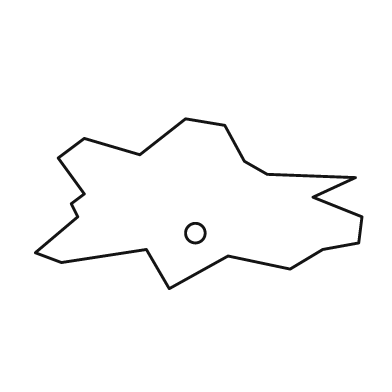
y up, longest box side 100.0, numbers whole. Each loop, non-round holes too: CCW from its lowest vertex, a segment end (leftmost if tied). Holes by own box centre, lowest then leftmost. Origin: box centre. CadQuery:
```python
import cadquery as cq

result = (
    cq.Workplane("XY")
    .moveTo(-9.0, -26.0)
    .lineTo(9.0, -16.0)
    .lineTo(28.0, -20.0)
    .lineTo(38.0, -14.0)
    .lineTo(49.0, -12.0)
    .lineTo(50.0, -4.0)
    .lineTo(35.0, 2.0)
    .lineTo(48.0, 8.0)
    .lineTo(21.0, 9.0)
    .lineTo(14.0, 13.0)
    .lineTo(8.0, 24.0)
    .lineTo(-4.0, 26.0)
    .lineTo(-18.0, 15.0)
    .lineTo(-35.0, 20.0)
    .lineTo(-43.0, 14.0)
    .lineTo(-35.0, 3.0)
    .lineTo(-39.0, 0.0)
    .lineTo(-37.0, -4.0)
    .lineTo(-50.0, -15.0)
    .lineTo(-42.0, -18.0)
    .lineTo(-16.0, -14.0)
    .close()
    .moveTo(-1.0, -9.0)
    .circle(3.0)
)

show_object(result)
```